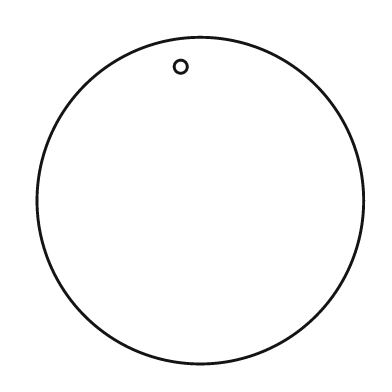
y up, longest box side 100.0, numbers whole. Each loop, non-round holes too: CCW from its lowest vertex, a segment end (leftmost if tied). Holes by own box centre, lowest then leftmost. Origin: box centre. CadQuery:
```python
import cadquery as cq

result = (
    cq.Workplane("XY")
    .moveTo(0.0, 0.0)
    .circle(50.0)
    .moveTo(-6.0, 41.0)
    .circle(2.0)
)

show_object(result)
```